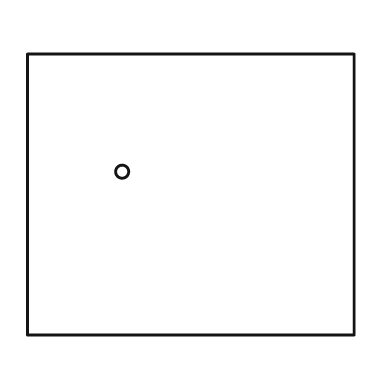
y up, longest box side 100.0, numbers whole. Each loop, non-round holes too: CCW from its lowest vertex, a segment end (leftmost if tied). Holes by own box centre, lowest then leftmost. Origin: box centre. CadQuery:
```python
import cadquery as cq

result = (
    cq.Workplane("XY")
    .moveTo(-50.0, -43.0)
    .lineTo(50.0, -43.0)
    .lineTo(50.0, 43.0)
    .lineTo(-50.0, 43.0)
    .close()
    .moveTo(-21.0, 7.0)
    .circle(2.0)
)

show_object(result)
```